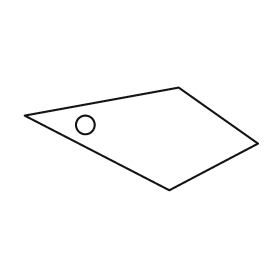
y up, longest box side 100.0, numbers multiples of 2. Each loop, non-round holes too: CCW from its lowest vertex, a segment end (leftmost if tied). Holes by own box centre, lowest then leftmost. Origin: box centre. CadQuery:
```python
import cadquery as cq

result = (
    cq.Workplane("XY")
    .moveTo(12.0, -22.0)
    .lineTo(50.0, -2.0)
    .lineTo(16.0, 22.0)
    .lineTo(-50.0, 10.0)
    .close()
    .moveTo(-24.0, 6.0)
    .circle(4.0)
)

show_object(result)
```